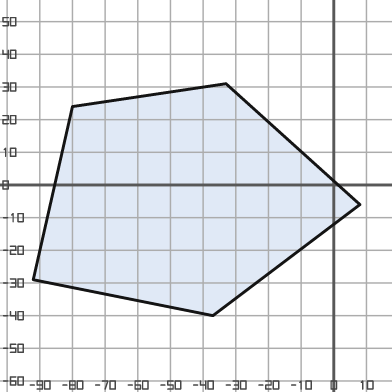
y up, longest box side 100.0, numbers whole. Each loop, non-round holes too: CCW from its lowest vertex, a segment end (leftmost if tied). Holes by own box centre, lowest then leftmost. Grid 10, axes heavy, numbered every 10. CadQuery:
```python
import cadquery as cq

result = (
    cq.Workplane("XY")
    .moveTo(-37.0, -40.0)
    .lineTo(8.0, -6.0)
    .lineTo(-33.0, 31.0)
    .lineTo(-80.0, 24.0)
    .lineTo(-92.0, -29.0)
    .close()
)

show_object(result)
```